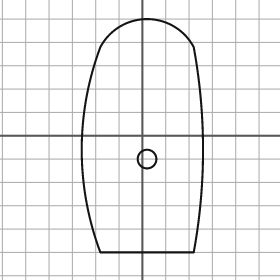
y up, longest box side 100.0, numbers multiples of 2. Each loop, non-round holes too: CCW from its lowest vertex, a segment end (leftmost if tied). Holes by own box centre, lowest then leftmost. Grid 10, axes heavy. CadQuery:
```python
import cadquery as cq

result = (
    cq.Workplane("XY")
    .moveTo(-18.0, -50.0)
    .lineTo(22.0, -50.0)
    .threePointArc((26.0, -6.0), (22.0, 38.0))
    .threePointArc((2.0, 50.0), (-18.0, 38.0))
    .threePointArc((-26.0, -6.0), (-18.0, -50.0))
    .close()
    .moveTo(2.0, -10.0)
    .circle(4.0)
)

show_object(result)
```